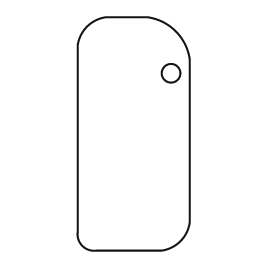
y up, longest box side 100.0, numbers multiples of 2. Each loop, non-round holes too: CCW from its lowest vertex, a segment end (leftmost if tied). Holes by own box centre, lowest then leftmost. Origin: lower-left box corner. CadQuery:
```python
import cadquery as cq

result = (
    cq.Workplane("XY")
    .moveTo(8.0, 0.0)
    .lineTo(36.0, 0.0)
    .threePointArc((44.0, 4.0), (48.0, 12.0))
    .lineTo(48.0, 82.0)
    .threePointArc((42.0, 94.0), (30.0, 100.0))
    .lineTo(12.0, 100.0)
    .threePointArc((4.0, 96.0), (0.0, 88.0))
    .lineTo(0.0, 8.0)
    .threePointArc((2.0, 2.0), (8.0, 0.0))
    .close()
    .moveTo(40.0, 76.0)
    .circle(4.0)
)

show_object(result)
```